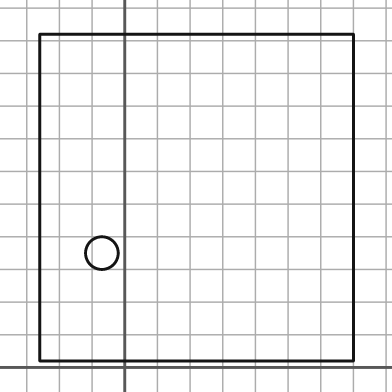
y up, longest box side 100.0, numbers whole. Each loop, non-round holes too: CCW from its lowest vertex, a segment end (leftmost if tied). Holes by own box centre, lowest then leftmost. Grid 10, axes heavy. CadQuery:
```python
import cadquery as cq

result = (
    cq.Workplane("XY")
    .moveTo(-26.0, 2.0)
    .lineTo(70.0, 2.0)
    .lineTo(70.0, 102.0)
    .lineTo(-26.0, 102.0)
    .close()
    .moveTo(-7.0, 35.0)
    .circle(5.0)
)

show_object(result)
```